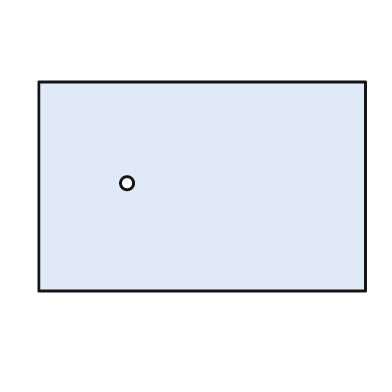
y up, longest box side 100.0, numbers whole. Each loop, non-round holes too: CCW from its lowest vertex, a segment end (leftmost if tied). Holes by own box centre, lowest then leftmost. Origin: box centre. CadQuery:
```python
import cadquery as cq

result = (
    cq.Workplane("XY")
    .moveTo(-50.0, -32.0)
    .lineTo(50.0, -32.0)
    .lineTo(50.0, 32.0)
    .lineTo(-50.0, 32.0)
    .close()
    .moveTo(-23.0, 1.0)
    .circle(2.0)
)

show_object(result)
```